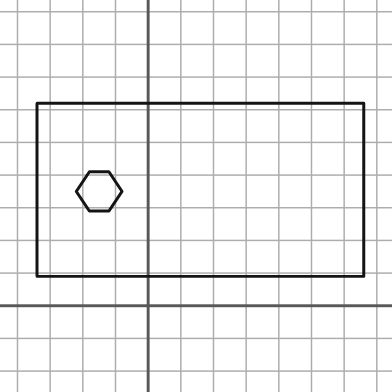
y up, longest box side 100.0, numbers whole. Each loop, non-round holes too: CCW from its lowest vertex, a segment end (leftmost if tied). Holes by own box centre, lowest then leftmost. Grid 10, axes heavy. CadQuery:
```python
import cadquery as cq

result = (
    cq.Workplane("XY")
    .moveTo(-34.0, 9.0)
    .lineTo(66.0, 9.0)
    .lineTo(66.0, 62.0)
    .lineTo(-34.0, 62.0)
    .close()
    .moveTo(-18.0, 29.0)
    .lineTo(-12.0, 29.0)
    .lineTo(-8.0, 35.0)
    .lineTo(-12.0, 41.0)
    .lineTo(-18.0, 41.0)
    .lineTo(-22.0, 35.0)
    .close()
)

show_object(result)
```